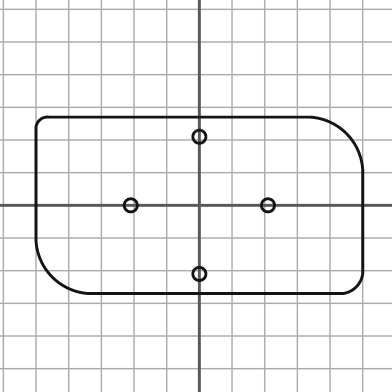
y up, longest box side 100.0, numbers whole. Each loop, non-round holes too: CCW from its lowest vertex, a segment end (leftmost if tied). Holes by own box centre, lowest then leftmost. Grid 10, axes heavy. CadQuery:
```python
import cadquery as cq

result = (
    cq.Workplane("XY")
    .moveTo(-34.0, -27.0)
    .lineTo(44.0, -27.0)
    .threePointArc((48.0, -25.0), (50.0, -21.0))
    .lineTo(50.0, 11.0)
    .threePointArc((45.0, 22.0), (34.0, 27.0))
    .lineTo(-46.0, 27.0)
    .threePointArc((-49.0, 26.0), (-50.0, 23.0))
    .lineTo(-50.0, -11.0)
    .threePointArc((-45.0, -22.0), (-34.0, -27.0))
    .close()
    .moveTo(0.0, -21.0)
    .circle(2.0)
    .moveTo(-21.0, 0.0)
    .circle(2.0)
    .moveTo(21.0, 0.0)
    .circle(2.0)
    .moveTo(0.0, 21.0)
    .circle(2.0)
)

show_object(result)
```